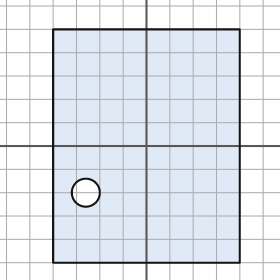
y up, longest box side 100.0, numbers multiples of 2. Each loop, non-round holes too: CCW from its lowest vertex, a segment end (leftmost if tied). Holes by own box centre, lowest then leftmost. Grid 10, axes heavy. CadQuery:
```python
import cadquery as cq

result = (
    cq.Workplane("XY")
    .moveTo(-40.0, -50.0)
    .lineTo(40.0, -50.0)
    .lineTo(40.0, 50.0)
    .lineTo(-40.0, 50.0)
    .close()
    .moveTo(-26.0, -20.0)
    .circle(6.0)
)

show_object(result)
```